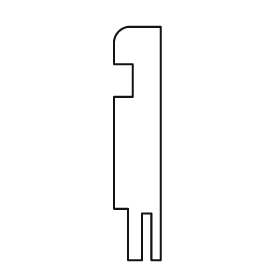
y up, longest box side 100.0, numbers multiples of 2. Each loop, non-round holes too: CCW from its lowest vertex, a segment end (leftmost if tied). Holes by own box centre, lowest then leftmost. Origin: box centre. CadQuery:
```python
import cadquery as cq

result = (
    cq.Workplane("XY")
    .moveTo(-4.0, -50.0)
    .lineTo(2.0, -50.0)
    .lineTo(2.0, -30.0)
    .lineTo(6.0, -30.0)
    .lineTo(6.0, -50.0)
    .lineTo(10.0, -50.0)
    .lineTo(10.0, 50.0)
    .lineTo(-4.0, 50.0)
    .threePointArc((-8.0, 48.0), (-10.0, 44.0))
    .lineTo(-10.0, 34.0)
    .lineTo(-2.0, 34.0)
    .lineTo(-2.0, 20.0)
    .lineTo(-10.0, 20.0)
    .lineTo(-10.0, -28.0)
    .lineTo(-4.0, -28.0)
    .close()
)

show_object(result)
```